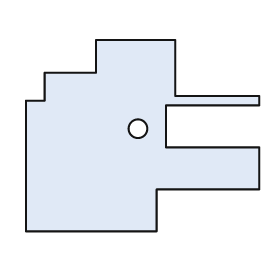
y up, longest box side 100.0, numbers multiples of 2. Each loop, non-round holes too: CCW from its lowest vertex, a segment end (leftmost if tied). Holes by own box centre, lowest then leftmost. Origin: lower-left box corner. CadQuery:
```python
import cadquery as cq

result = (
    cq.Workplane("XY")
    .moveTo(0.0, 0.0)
    .lineTo(56.0, 0.0)
    .lineTo(56.0, 18.0)
    .lineTo(100.0, 18.0)
    .lineTo(100.0, 36.0)
    .lineTo(60.0, 36.0)
    .lineTo(60.0, 54.0)
    .lineTo(100.0, 54.0)
    .lineTo(100.0, 58.0)
    .lineTo(64.0, 58.0)
    .lineTo(64.0, 82.0)
    .lineTo(30.0, 82.0)
    .lineTo(30.0, 68.0)
    .lineTo(8.0, 68.0)
    .lineTo(8.0, 56.0)
    .lineTo(0.0, 56.0)
    .close()
    .moveTo(48.0, 44.0)
    .circle(4.0)
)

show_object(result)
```